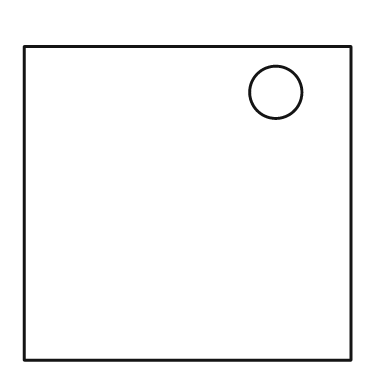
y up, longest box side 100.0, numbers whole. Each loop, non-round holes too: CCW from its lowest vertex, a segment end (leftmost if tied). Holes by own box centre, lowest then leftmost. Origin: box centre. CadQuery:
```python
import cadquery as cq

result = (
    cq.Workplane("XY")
    .moveTo(-50.0, -48.0)
    .lineTo(50.0, -48.0)
    .lineTo(50.0, 48.0)
    .lineTo(-50.0, 48.0)
    .close()
    .moveTo(27.0, 34.0)
    .circle(8.0)
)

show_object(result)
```